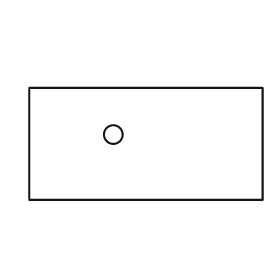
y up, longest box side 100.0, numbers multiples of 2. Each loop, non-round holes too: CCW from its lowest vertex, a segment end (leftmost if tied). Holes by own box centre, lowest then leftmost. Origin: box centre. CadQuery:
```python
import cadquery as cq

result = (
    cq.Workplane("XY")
    .moveTo(-50.0, -24.0)
    .lineTo(50.0, -24.0)
    .lineTo(50.0, 24.0)
    .lineTo(-50.0, 24.0)
    .close()
    .moveTo(-14.0, 4.0)
    .circle(4.0)
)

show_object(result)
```